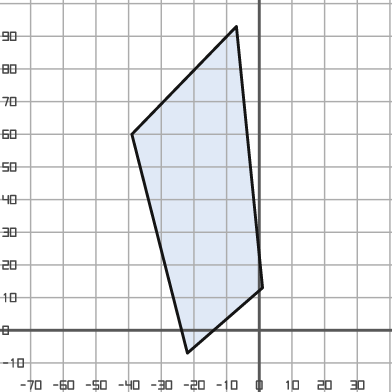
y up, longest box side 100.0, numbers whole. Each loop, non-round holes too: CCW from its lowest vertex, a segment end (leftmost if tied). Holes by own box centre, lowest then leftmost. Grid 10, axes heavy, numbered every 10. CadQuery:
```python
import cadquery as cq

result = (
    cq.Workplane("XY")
    .moveTo(-22.0, -7.0)
    .lineTo(1.0, 13.0)
    .lineTo(-7.0, 93.0)
    .lineTo(-39.0, 60.0)
    .close()
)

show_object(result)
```